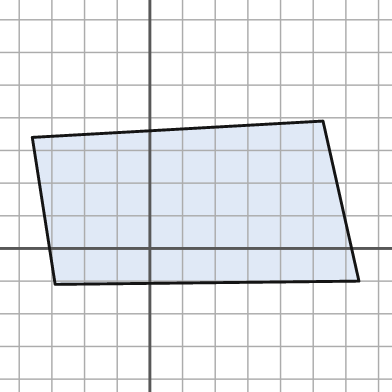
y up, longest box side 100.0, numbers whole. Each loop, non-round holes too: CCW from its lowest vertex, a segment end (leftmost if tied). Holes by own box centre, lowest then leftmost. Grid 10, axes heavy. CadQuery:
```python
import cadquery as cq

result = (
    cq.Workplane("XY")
    .moveTo(-29.0, -11.0)
    .lineTo(64.0, -10.0)
    .lineTo(53.0, 39.0)
    .lineTo(-36.0, 34.0)
    .close()
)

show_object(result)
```